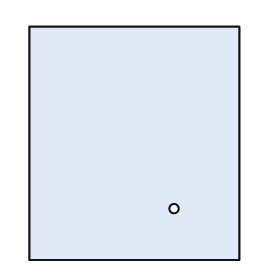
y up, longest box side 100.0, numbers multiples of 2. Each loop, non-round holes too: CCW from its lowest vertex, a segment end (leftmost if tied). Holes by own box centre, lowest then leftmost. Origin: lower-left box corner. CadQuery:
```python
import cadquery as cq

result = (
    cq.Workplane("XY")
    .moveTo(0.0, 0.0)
    .lineTo(90.0, 0.0)
    .lineTo(90.0, 100.0)
    .lineTo(0.0, 100.0)
    .close()
    .moveTo(62.0, 22.0)
    .circle(2.0)
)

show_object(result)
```